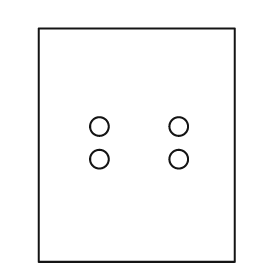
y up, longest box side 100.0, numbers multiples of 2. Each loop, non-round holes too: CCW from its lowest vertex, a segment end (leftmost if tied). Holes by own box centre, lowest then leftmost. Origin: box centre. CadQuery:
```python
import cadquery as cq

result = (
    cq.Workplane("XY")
    .moveTo(-42.0, -50.0)
    .lineTo(42.0, -50.0)
    .lineTo(42.0, 50.0)
    .lineTo(-42.0, 50.0)
    .close()
    .moveTo(-16.0, -6.0)
    .circle(4.0)
    .moveTo(18.0, -6.0)
    .circle(4.0)
    .moveTo(-16.0, 8.0)
    .circle(4.0)
    .moveTo(18.0, 8.0)
    .circle(4.0)
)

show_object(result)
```